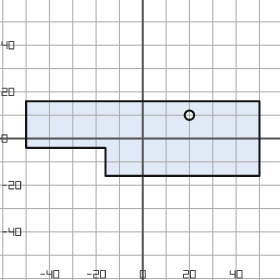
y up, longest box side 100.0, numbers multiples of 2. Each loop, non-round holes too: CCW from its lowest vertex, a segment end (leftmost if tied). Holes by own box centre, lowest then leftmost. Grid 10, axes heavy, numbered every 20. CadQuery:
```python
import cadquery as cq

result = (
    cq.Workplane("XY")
    .moveTo(-16.0, -16.0)
    .lineTo(50.0, -16.0)
    .lineTo(50.0, 16.0)
    .lineTo(-50.0, 16.0)
    .lineTo(-50.0, -4.0)
    .lineTo(-16.0, -4.0)
    .close()
    .moveTo(20.0, 10.0)
    .circle(2.0)
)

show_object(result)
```